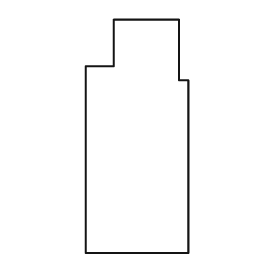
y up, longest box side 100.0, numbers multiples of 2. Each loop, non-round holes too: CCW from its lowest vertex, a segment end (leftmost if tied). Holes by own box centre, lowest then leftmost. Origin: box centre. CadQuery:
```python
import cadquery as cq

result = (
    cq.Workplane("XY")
    .moveTo(-22.0, -50.0)
    .lineTo(22.0, -50.0)
    .lineTo(22.0, 24.0)
    .lineTo(18.0, 24.0)
    .lineTo(18.0, 50.0)
    .lineTo(-10.0, 50.0)
    .lineTo(-10.0, 30.0)
    .lineTo(-22.0, 30.0)
    .close()
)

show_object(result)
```